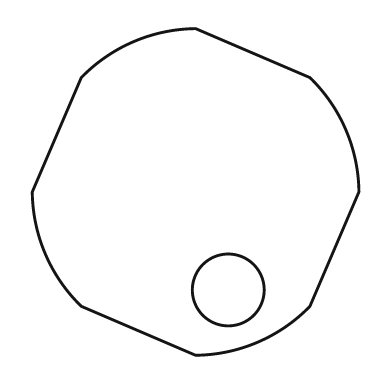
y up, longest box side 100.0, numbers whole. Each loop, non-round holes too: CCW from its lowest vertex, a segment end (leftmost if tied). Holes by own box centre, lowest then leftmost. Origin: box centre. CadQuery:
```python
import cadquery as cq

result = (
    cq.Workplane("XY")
    .moveTo(0.0, -50.0)
    .threePointArc((19.0, -46.0), (35.0, -35.0))
    .lineTo(50.0, 0.0)
    .threePointArc((46.0, 19.0), (35.0, 35.0))
    .lineTo(0.0, 50.0)
    .threePointArc((-19.0, 46.0), (-35.0, 35.0))
    .lineTo(-50.0, 0.0)
    .threePointArc((-46.0, -19.0), (-35.0, -35.0))
    .close()
    .moveTo(10.0, -30.0)
    .circle(11.0)
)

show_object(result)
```